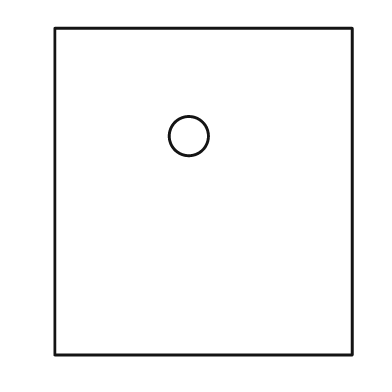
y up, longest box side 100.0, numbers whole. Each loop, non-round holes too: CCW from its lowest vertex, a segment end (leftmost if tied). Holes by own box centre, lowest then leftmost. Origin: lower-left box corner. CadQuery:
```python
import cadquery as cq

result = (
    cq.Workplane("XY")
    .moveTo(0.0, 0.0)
    .lineTo(91.0, 0.0)
    .lineTo(91.0, 100.0)
    .lineTo(0.0, 100.0)
    .close()
    .moveTo(41.0, 67.0)
    .circle(6.0)
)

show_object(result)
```